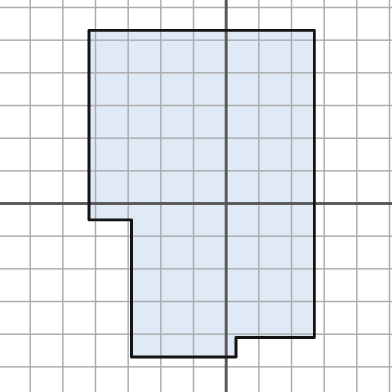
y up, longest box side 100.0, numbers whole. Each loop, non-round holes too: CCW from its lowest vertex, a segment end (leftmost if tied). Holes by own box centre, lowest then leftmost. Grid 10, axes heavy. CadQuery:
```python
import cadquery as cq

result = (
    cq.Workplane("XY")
    .moveTo(-29.0, -47.0)
    .lineTo(3.0, -47.0)
    .lineTo(3.0, -41.0)
    .lineTo(27.0, -41.0)
    .lineTo(27.0, 53.0)
    .lineTo(-42.0, 53.0)
    .lineTo(-42.0, -5.0)
    .lineTo(-29.0, -5.0)
    .close()
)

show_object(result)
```